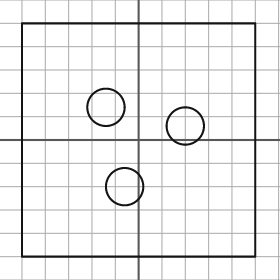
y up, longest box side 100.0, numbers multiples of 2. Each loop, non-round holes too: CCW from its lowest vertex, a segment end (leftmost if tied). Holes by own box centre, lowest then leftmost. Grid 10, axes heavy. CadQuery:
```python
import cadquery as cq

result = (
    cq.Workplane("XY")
    .moveTo(-50.0, -50.0)
    .lineTo(50.0, -50.0)
    .lineTo(50.0, 50.0)
    .lineTo(-50.0, 50.0)
    .close()
    .moveTo(-6.0, -20.0)
    .circle(8.0)
    .moveTo(20.0, 6.0)
    .circle(8.0)
    .moveTo(-14.0, 14.0)
    .circle(8.0)
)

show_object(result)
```